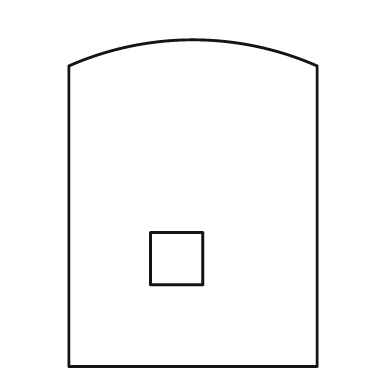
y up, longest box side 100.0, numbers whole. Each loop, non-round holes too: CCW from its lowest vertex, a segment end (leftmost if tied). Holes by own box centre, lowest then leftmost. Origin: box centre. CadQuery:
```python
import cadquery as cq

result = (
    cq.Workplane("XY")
    .moveTo(-38.0, -50.0)
    .lineTo(38.0, -50.0)
    .lineTo(38.0, 42.0)
    .threePointArc((0.0, 50.0), (-38.0, 42.0))
    .close()
    .moveTo(-13.0, -25.0)
    .lineTo(3.0, -25.0)
    .lineTo(3.0, -9.0)
    .lineTo(-13.0, -9.0)
    .close()
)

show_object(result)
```